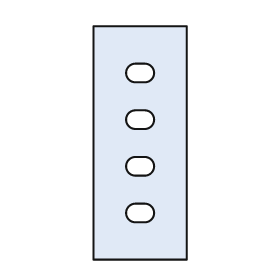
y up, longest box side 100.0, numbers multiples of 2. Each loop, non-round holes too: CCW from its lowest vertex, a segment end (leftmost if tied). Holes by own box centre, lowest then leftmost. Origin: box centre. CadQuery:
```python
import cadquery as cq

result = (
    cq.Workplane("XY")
    .moveTo(-20.0, -50.0)
    .lineTo(20.0, -50.0)
    .lineTo(20.0, 50.0)
    .lineTo(-20.0, 50.0)
    .close()
    .moveTo(-2.0, -34.0)
    .lineTo(2.0, -34.0)
    .threePointArc((6.0, -30.0), (2.0, -26.0))
    .lineTo(-2.0, -26.0)
    .threePointArc((-6.0, -30.0), (-2.0, -34.0))
    .close()
    .moveTo(-2.0, -14.0)
    .lineTo(2.0, -14.0)
    .threePointArc((6.0, -10.0), (2.0, -6.0))
    .lineTo(-2.0, -6.0)
    .threePointArc((-6.0, -10.0), (-2.0, -14.0))
    .close()
    .moveTo(-2.0, 6.0)
    .lineTo(2.0, 6.0)
    .threePointArc((6.0, 10.0), (2.0, 14.0))
    .lineTo(-2.0, 14.0)
    .threePointArc((-6.0, 10.0), (-2.0, 6.0))
    .close()
    .moveTo(-2.0, 26.0)
    .lineTo(2.0, 26.0)
    .threePointArc((6.0, 30.0), (2.0, 34.0))
    .lineTo(-2.0, 34.0)
    .threePointArc((-6.0, 30.0), (-2.0, 26.0))
    .close()
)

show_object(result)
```